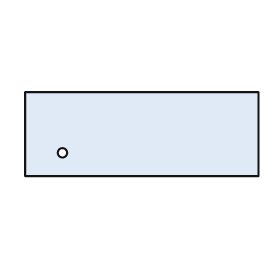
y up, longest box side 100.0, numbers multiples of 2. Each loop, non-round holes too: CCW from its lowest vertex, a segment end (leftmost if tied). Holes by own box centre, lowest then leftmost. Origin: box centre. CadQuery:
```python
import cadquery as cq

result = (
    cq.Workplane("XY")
    .moveTo(-50.0, -18.0)
    .lineTo(50.0, -18.0)
    .lineTo(50.0, 18.0)
    .lineTo(-50.0, 18.0)
    .close()
    .moveTo(-34.0, -8.0)
    .circle(2.0)
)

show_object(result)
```